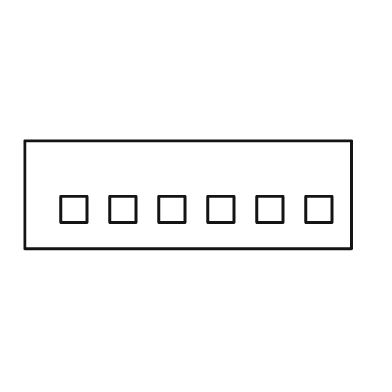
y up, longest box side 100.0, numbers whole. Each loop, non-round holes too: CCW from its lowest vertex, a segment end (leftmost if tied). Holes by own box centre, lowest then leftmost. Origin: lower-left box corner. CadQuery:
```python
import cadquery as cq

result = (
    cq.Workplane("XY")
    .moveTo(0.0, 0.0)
    .lineTo(100.0, 0.0)
    .lineTo(100.0, 33.0)
    .lineTo(0.0, 33.0)
    .close()
    .moveTo(11.0, 8.0)
    .lineTo(19.0, 8.0)
    .lineTo(19.0, 16.0)
    .lineTo(11.0, 16.0)
    .close()
    .moveTo(26.0, 8.0)
    .lineTo(34.0, 8.0)
    .lineTo(34.0, 16.0)
    .lineTo(26.0, 16.0)
    .close()
    .moveTo(41.0, 8.0)
    .lineTo(49.0, 8.0)
    .lineTo(49.0, 16.0)
    .lineTo(41.0, 16.0)
    .close()
    .moveTo(56.0, 8.0)
    .lineTo(64.0, 8.0)
    .lineTo(64.0, 16.0)
    .lineTo(56.0, 16.0)
    .close()
    .moveTo(71.0, 8.0)
    .lineTo(79.0, 8.0)
    .lineTo(79.0, 16.0)
    .lineTo(71.0, 16.0)
    .close()
    .moveTo(86.0, 8.0)
    .lineTo(94.0, 8.0)
    .lineTo(94.0, 16.0)
    .lineTo(86.0, 16.0)
    .close()
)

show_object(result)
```